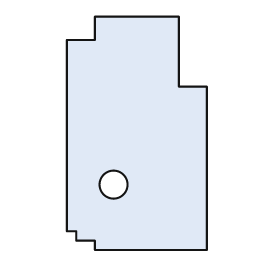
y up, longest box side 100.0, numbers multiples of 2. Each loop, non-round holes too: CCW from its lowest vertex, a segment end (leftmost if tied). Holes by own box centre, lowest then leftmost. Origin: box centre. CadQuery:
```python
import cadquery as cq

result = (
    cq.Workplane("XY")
    .moveTo(-18.0, -50.0)
    .lineTo(30.0, -50.0)
    .lineTo(30.0, 20.0)
    .lineTo(18.0, 20.0)
    .lineTo(18.0, 50.0)
    .lineTo(-18.0, 50.0)
    .lineTo(-18.0, 40.0)
    .lineTo(-30.0, 40.0)
    .lineTo(-30.0, -42.0)
    .lineTo(-26.0, -42.0)
    .lineTo(-26.0, -46.0)
    .lineTo(-18.0, -46.0)
    .close()
    .moveTo(-10.0, -22.0)
    .circle(6.0)
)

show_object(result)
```